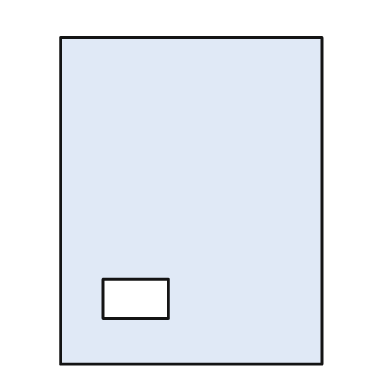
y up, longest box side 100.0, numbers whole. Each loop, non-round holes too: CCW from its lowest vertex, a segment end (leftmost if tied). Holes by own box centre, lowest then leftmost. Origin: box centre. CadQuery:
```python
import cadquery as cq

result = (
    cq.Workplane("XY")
    .moveTo(-40.0, -50.0)
    .lineTo(40.0, -50.0)
    .lineTo(40.0, 50.0)
    .lineTo(-40.0, 50.0)
    .close()
    .moveTo(-27.0, -36.0)
    .lineTo(-7.0, -36.0)
    .lineTo(-7.0, -24.0)
    .lineTo(-27.0, -24.0)
    .close()
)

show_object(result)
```